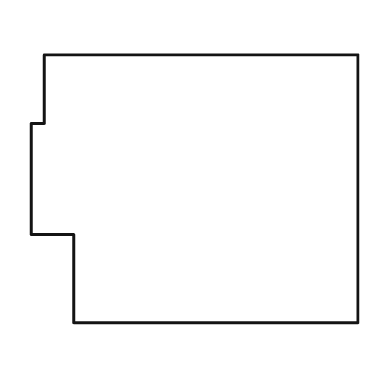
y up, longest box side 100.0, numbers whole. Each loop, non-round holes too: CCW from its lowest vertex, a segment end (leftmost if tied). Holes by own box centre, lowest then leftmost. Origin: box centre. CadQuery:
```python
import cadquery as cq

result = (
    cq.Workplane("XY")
    .moveTo(-37.0, -41.0)
    .lineTo(50.0, -41.0)
    .lineTo(50.0, 41.0)
    .lineTo(-46.0, 41.0)
    .lineTo(-46.0, 20.0)
    .lineTo(-50.0, 20.0)
    .lineTo(-50.0, -14.0)
    .lineTo(-37.0, -14.0)
    .close()
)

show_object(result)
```